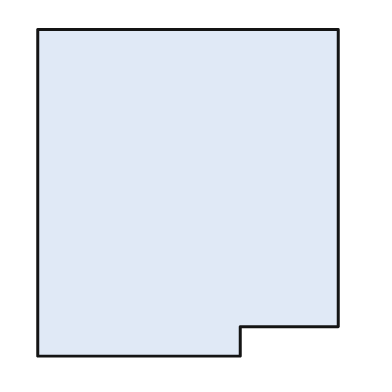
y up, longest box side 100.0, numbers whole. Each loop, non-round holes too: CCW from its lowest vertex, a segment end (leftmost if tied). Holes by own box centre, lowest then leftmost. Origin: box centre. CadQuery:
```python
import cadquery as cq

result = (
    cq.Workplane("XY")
    .moveTo(-46.0, -50.0)
    .lineTo(16.0, -50.0)
    .lineTo(16.0, -41.0)
    .lineTo(46.0, -41.0)
    .lineTo(46.0, 50.0)
    .lineTo(-46.0, 50.0)
    .close()
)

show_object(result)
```